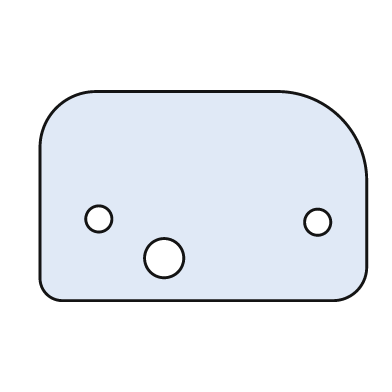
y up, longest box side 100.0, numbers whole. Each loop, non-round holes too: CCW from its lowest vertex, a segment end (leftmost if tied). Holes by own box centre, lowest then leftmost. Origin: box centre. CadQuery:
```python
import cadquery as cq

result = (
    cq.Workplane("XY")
    .moveTo(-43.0, -32.0)
    .lineTo(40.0, -32.0)
    .threePointArc((47.0, -29.0), (50.0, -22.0))
    .lineTo(50.0, 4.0)
    .threePointArc((42.0, 24.0), (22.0, 32.0))
    .lineTo(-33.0, 32.0)
    .threePointArc((-45.0, 27.0), (-50.0, 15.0))
    .lineTo(-50.0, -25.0)
    .threePointArc((-48.0, -30.0), (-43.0, -32.0))
    .close()
    .moveTo(-12.0, -19.0)
    .circle(6.0)
    .moveTo(35.0, -8.0)
    .circle(4.0)
    .moveTo(-32.0, -7.0)
    .circle(4.0)
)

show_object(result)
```